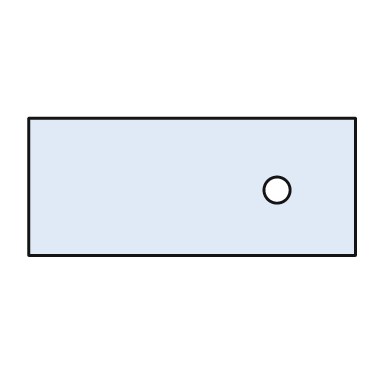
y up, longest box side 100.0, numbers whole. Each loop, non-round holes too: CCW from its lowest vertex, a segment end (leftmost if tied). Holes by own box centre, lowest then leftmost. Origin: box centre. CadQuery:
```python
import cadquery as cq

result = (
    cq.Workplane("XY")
    .moveTo(-50.0, -21.0)
    .lineTo(50.0, -21.0)
    .lineTo(50.0, 21.0)
    .lineTo(-50.0, 21.0)
    .close()
    .moveTo(26.0, -1.0)
    .circle(4.0)
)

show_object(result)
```